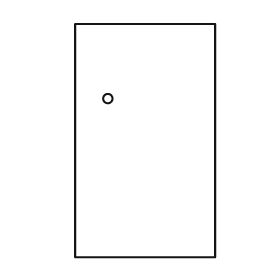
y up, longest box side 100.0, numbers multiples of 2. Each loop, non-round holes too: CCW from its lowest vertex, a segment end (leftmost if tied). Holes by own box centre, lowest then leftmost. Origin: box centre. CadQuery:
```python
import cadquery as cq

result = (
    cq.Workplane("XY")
    .moveTo(-30.0, -50.0)
    .lineTo(30.0, -50.0)
    .lineTo(30.0, 50.0)
    .lineTo(-30.0, 50.0)
    .close()
    .moveTo(-16.0, 18.0)
    .circle(2.0)
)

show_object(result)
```